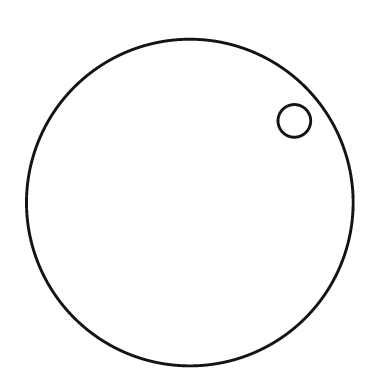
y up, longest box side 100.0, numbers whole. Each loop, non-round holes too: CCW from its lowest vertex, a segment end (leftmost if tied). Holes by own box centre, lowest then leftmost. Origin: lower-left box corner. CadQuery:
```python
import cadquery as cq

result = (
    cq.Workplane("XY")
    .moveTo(50.0, 50.0)
    .circle(50.0)
    .moveTo(82.0, 75.0)
    .circle(5.0)
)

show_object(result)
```